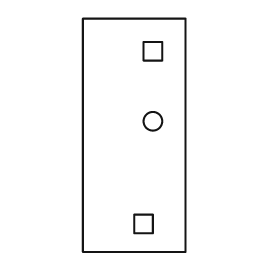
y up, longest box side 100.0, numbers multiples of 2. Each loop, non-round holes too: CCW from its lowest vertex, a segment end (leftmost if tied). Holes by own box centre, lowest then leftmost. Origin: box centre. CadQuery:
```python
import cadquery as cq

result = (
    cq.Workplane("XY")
    .moveTo(-22.0, -50.0)
    .lineTo(22.0, -50.0)
    .lineTo(22.0, 50.0)
    .lineTo(-22.0, 50.0)
    .close()
    .moveTo(0.0, -42.0)
    .lineTo(8.0, -42.0)
    .lineTo(8.0, -34.0)
    .lineTo(0.0, -34.0)
    .close()
    .moveTo(8.0, 6.0)
    .circle(4.0)
    .moveTo(4.0, 32.0)
    .lineTo(12.0, 32.0)
    .lineTo(12.0, 40.0)
    .lineTo(4.0, 40.0)
    .close()
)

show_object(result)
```